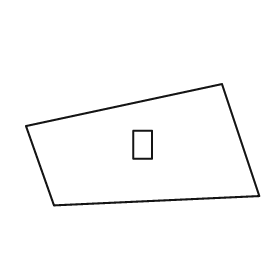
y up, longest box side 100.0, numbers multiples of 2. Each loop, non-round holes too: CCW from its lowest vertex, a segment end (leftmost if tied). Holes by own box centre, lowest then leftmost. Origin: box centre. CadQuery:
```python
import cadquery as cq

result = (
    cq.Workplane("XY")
    .moveTo(-38.0, -26.0)
    .lineTo(50.0, -22.0)
    .lineTo(34.0, 26.0)
    .lineTo(-50.0, 8.0)
    .close()
    .moveTo(-4.0, -6.0)
    .lineTo(4.0, -6.0)
    .lineTo(4.0, 6.0)
    .lineTo(-4.0, 6.0)
    .close()
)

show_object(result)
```